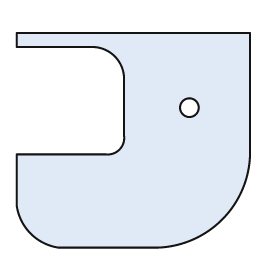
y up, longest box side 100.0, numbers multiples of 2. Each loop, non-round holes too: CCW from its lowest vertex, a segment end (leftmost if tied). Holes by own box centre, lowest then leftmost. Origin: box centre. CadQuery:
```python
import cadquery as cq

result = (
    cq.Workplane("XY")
    .moveTo(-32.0, -46.0)
    .lineTo(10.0, -46.0)
    .threePointArc((38.0, -34.0), (50.0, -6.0))
    .lineTo(50.0, 46.0)
    .lineTo(-50.0, 46.0)
    .lineTo(-50.0, 40.0)
    .lineTo(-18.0, 40.0)
    .threePointArc((-8.0, 36.0), (-4.0, 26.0))
    .lineTo(-4.0, 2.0)
    .threePointArc((-6.0, -4.0), (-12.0, -6.0))
    .lineTo(-50.0, -6.0)
    .lineTo(-50.0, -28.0)
    .threePointArc((-44.0, -40.0), (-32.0, -46.0))
    .close()
    .moveTo(24.0, 14.0)
    .circle(4.0)
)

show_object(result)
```